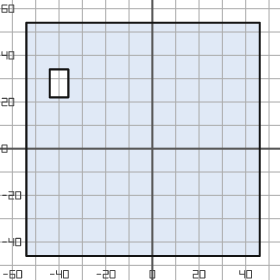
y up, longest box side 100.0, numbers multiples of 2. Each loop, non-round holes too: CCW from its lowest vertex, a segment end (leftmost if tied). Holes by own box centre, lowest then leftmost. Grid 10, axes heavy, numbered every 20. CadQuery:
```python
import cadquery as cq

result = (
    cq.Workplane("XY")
    .moveTo(-54.0, -46.0)
    .lineTo(46.0, -46.0)
    .lineTo(46.0, 54.0)
    .lineTo(-54.0, 54.0)
    .close()
    .moveTo(-44.0, 22.0)
    .lineTo(-36.0, 22.0)
    .lineTo(-36.0, 34.0)
    .lineTo(-44.0, 34.0)
    .close()
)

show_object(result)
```